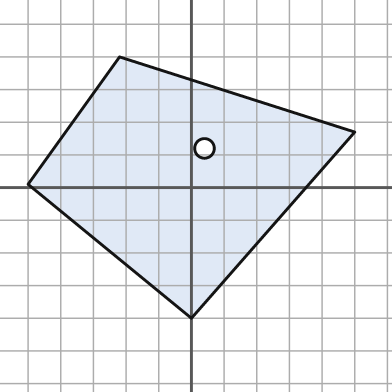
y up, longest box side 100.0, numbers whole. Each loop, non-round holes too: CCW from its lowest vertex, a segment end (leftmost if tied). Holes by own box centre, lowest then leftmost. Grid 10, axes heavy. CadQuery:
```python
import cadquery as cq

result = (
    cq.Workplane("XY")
    .moveTo(0.0, -40.0)
    .lineTo(50.0, 17.0)
    .lineTo(-22.0, 40.0)
    .lineTo(-50.0, 1.0)
    .close()
    .moveTo(4.0, 12.0)
    .circle(3.0)
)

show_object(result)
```